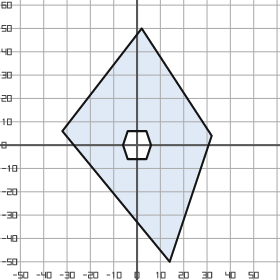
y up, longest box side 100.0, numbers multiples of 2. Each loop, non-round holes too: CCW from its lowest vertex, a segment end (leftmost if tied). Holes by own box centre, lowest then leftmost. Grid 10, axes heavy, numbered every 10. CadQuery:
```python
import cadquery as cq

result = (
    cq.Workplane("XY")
    .moveTo(14.0, -50.0)
    .lineTo(32.0, 4.0)
    .lineTo(2.0, 50.0)
    .lineTo(-32.0, 6.0)
    .close()
    .moveTo(-4.0, -6.0)
    .lineTo(4.0, -6.0)
    .lineTo(6.0, 0.0)
    .lineTo(4.0, 6.0)
    .lineTo(-4.0, 6.0)
    .lineTo(-6.0, 0.0)
    .close()
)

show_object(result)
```